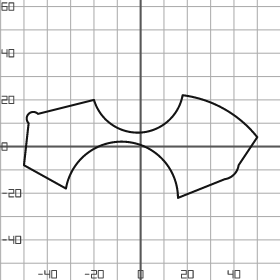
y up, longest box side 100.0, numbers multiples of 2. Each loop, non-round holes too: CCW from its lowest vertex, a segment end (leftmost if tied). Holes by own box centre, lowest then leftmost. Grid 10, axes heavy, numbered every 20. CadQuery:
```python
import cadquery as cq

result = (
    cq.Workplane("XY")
    .moveTo(16.0, -22.0)
    .lineTo(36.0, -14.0)
    .threePointArc((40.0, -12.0), (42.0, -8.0))
    .lineTo(50.0, 4.0)
    .threePointArc((36.0, 16.0), (18.0, 22.0))
    .threePointArc((0.0, 6.0), (-20.0, 20.0))
    .lineTo(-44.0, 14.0)
    .threePointArc((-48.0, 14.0), (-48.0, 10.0))
    .lineTo(-50.0, -8.0)
    .lineTo(-32.0, -18.0)
    .threePointArc((-6.0, 2.0), (16.0, -22.0))
    .close()
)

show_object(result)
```